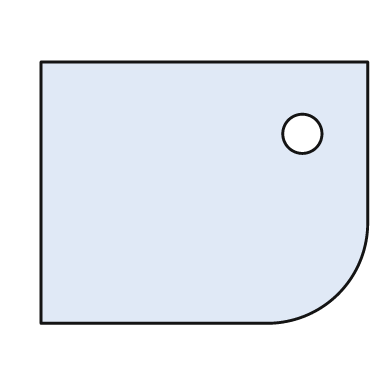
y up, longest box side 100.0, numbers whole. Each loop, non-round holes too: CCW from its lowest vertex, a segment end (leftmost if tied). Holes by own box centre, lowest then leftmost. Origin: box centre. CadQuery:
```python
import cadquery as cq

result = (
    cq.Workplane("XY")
    .moveTo(-50.0, -40.0)
    .lineTo(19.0, -40.0)
    .threePointArc((41.0, -31.0), (50.0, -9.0))
    .lineTo(50.0, 40.0)
    .lineTo(-50.0, 40.0)
    .close()
    .moveTo(30.0, 18.0)
    .circle(6.0)
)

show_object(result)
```